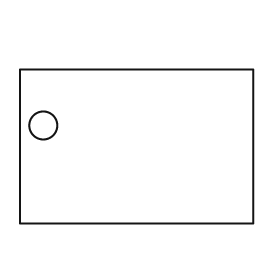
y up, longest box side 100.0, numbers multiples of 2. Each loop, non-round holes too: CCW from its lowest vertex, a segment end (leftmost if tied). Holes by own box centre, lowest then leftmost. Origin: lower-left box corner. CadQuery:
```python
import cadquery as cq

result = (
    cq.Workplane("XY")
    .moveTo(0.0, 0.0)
    .lineTo(100.0, 0.0)
    .lineTo(100.0, 66.0)
    .lineTo(0.0, 66.0)
    .close()
    .moveTo(10.0, 42.0)
    .circle(6.0)
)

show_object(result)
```